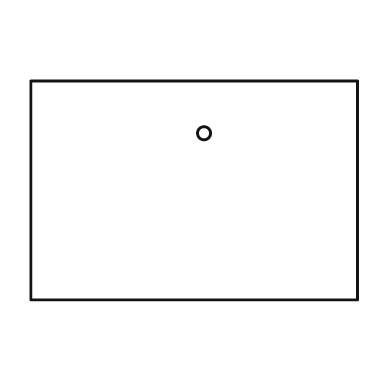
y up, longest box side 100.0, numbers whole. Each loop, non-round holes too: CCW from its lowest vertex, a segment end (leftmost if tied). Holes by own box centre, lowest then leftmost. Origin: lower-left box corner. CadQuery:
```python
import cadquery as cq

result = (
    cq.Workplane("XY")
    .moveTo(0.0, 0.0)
    .lineTo(100.0, 0.0)
    .lineTo(100.0, 67.0)
    .lineTo(0.0, 67.0)
    .close()
    .moveTo(53.0, 51.0)
    .circle(2.0)
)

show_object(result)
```